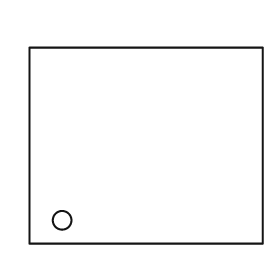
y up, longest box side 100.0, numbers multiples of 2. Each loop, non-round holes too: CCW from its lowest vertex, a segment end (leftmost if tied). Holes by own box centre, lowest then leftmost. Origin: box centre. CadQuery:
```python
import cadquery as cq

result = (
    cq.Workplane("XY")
    .moveTo(-50.0, -42.0)
    .lineTo(50.0, -42.0)
    .lineTo(50.0, 42.0)
    .lineTo(-50.0, 42.0)
    .close()
    .moveTo(-36.0, -32.0)
    .circle(4.0)
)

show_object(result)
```